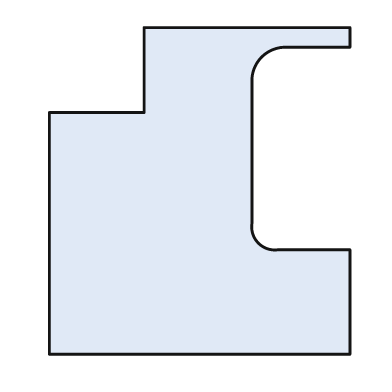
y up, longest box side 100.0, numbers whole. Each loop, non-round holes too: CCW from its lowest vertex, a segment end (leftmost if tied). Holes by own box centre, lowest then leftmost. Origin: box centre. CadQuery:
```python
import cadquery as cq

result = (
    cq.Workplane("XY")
    .moveTo(-46.0, -50.0)
    .lineTo(46.0, -50.0)
    .lineTo(46.0, -18.0)
    .lineTo(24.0, -18.0)
    .threePointArc((18.0, -16.0), (16.0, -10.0))
    .lineTo(16.0, 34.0)
    .threePointArc((19.0, 41.0), (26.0, 44.0))
    .lineTo(46.0, 44.0)
    .lineTo(46.0, 50.0)
    .lineTo(-17.0, 50.0)
    .lineTo(-17.0, 24.0)
    .lineTo(-46.0, 24.0)
    .close()
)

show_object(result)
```